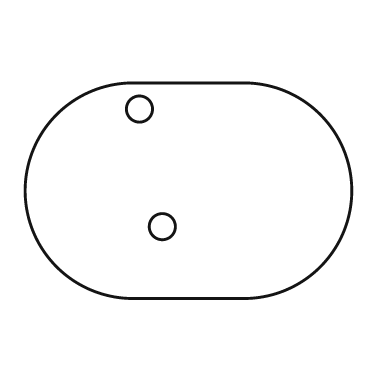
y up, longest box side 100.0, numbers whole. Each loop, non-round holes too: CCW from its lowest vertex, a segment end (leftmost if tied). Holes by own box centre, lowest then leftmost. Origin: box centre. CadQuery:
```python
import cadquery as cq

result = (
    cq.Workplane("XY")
    .moveTo(-17.0, -33.0)
    .lineTo(17.0, -33.0)
    .threePointArc((50.0, 0.0), (17.0, 33.0))
    .lineTo(-17.0, 33.0)
    .threePointArc((-50.0, 0.0), (-17.0, -33.0))
    .close()
    .moveTo(-8.0, -11.0)
    .circle(4.0)
    .moveTo(-15.0, 25.0)
    .circle(4.0)
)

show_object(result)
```